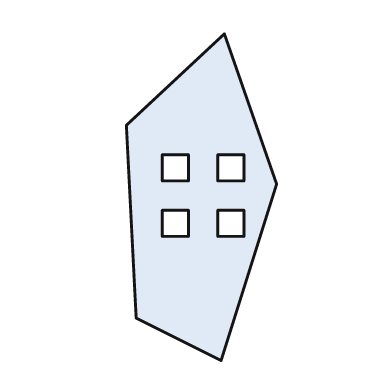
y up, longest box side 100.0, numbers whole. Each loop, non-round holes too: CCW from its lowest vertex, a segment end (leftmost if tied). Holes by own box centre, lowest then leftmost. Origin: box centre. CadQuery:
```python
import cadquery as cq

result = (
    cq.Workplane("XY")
    .moveTo(6.0, -50.0)
    .lineTo(23.0, 4.0)
    .lineTo(7.0, 50.0)
    .lineTo(-23.0, 22.0)
    .lineTo(-20.0, -37.0)
    .close()
    .moveTo(-12.0, -12.0)
    .lineTo(-4.0, -12.0)
    .lineTo(-4.0, -4.0)
    .lineTo(-12.0, -4.0)
    .close()
    .moveTo(5.0, -12.0)
    .lineTo(13.0, -12.0)
    .lineTo(13.0, -4.0)
    .lineTo(5.0, -4.0)
    .close()
    .moveTo(-12.0, 5.0)
    .lineTo(-4.0, 5.0)
    .lineTo(-4.0, 13.0)
    .lineTo(-12.0, 13.0)
    .close()
    .moveTo(5.0, 5.0)
    .lineTo(13.0, 5.0)
    .lineTo(13.0, 13.0)
    .lineTo(5.0, 13.0)
    .close()
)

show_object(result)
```